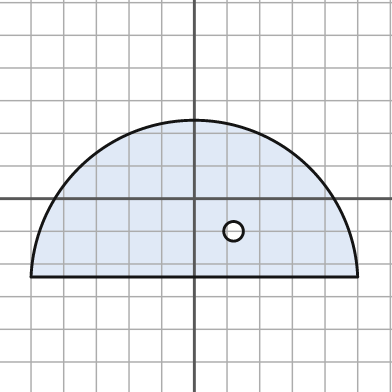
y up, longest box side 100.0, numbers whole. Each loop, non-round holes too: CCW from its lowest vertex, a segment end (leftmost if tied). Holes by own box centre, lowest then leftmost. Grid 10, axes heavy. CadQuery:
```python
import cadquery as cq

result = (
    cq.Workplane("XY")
    .moveTo(-50.0, -24.0)
    .lineTo(50.0, -24.0)
    .threePointArc((0.0, 24.0), (-50.0, -24.0))
    .close()
    .moveTo(12.0, -10.0)
    .circle(3.0)
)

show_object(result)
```